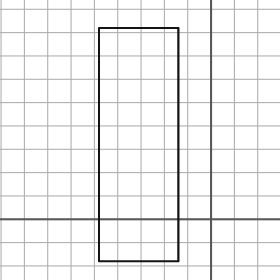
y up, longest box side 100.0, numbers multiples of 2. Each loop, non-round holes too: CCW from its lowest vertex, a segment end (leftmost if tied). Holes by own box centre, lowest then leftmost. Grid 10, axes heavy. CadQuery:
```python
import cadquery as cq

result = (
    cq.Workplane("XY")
    .moveTo(-48.0, -18.0)
    .lineTo(-14.0, -18.0)
    .lineTo(-14.0, 82.0)
    .lineTo(-48.0, 82.0)
    .close()
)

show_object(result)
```